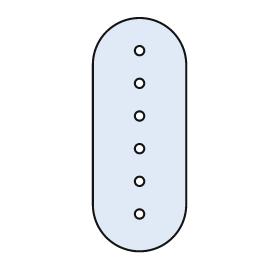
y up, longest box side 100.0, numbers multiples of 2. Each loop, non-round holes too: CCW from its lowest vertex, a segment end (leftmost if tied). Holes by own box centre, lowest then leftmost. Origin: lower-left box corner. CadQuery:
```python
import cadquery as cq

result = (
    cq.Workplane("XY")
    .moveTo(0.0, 20.0)
    .threePointArc((20.0, 0.0), (40.0, 20.0))
    .lineTo(40.0, 80.0)
    .threePointArc((20.0, 100.0), (0.0, 80.0))
    .close()
    .moveTo(20.0, 16.0)
    .circle(2.0)
    .moveTo(20.0, 30.0)
    .circle(2.0)
    .moveTo(20.0, 44.0)
    .circle(2.0)
    .moveTo(20.0, 58.0)
    .circle(2.0)
    .moveTo(20.0, 72.0)
    .circle(2.0)
    .moveTo(20.0, 86.0)
    .circle(2.0)
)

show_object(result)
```